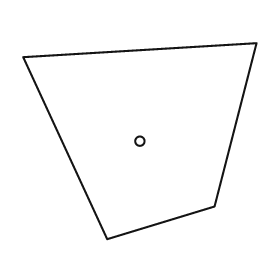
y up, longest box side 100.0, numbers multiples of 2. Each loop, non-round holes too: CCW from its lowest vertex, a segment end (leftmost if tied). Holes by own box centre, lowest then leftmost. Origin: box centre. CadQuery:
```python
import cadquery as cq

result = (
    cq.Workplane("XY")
    .moveTo(-14.0, -42.0)
    .lineTo(32.0, -28.0)
    .lineTo(50.0, 42.0)
    .lineTo(-50.0, 36.0)
    .close()
    .moveTo(0.0, 0.0)
    .circle(2.0)
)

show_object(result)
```